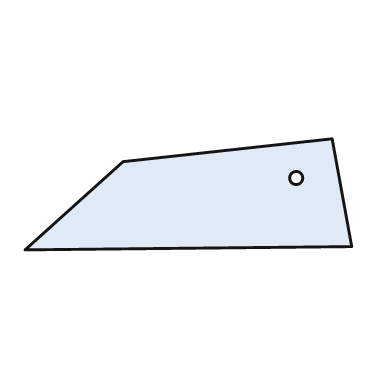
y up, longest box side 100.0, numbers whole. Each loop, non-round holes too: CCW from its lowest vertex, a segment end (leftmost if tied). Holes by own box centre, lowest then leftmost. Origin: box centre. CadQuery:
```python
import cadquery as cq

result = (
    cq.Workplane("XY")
    .moveTo(-50.0, -17.0)
    .lineTo(50.0, -16.0)
    .lineTo(44.0, 17.0)
    .lineTo(-20.0, 10.0)
    .close()
    .moveTo(33.0, 5.0)
    .circle(2.0)
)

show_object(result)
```